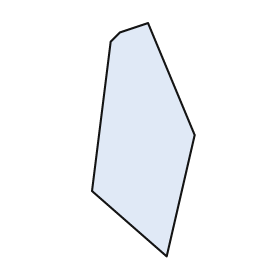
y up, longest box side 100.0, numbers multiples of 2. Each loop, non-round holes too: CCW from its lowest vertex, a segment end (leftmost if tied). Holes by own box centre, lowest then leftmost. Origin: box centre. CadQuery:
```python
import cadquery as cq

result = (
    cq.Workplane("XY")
    .moveTo(10.0, -50.0)
    .lineTo(22.0, 2.0)
    .lineTo(2.0, 50.0)
    .lineTo(-10.0, 46.0)
    .lineTo(-14.0, 42.0)
    .lineTo(-22.0, -22.0)
    .close()
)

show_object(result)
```